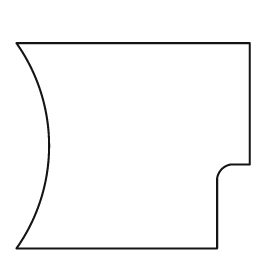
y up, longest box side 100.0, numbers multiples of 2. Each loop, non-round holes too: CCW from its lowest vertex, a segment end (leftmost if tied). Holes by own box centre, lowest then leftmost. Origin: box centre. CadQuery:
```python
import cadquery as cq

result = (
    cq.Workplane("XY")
    .moveTo(-50.0, -44.0)
    .lineTo(36.0, -44.0)
    .lineTo(36.0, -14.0)
    .threePointArc((38.0, -10.0), (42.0, -8.0))
    .lineTo(50.0, -8.0)
    .lineTo(50.0, 44.0)
    .lineTo(-50.0, 44.0)
    .threePointArc((-36.0, 0.0), (-50.0, -44.0))
    .close()
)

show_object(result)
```